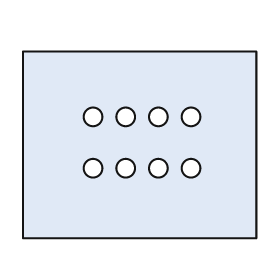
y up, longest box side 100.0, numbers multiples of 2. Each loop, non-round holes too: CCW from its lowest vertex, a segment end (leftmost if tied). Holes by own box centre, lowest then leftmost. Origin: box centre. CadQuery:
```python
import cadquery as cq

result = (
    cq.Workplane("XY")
    .moveTo(-50.0, -40.0)
    .lineTo(50.0, -40.0)
    .lineTo(50.0, 40.0)
    .lineTo(-50.0, 40.0)
    .close()
    .moveTo(-20.0, -10.0)
    .circle(4.0)
    .moveTo(-6.0, -10.0)
    .circle(4.0)
    .moveTo(8.0, -10.0)
    .circle(4.0)
    .moveTo(22.0, -10.0)
    .circle(4.0)
    .moveTo(-20.0, 12.0)
    .circle(4.0)
    .moveTo(-6.0, 12.0)
    .circle(4.0)
    .moveTo(8.0, 12.0)
    .circle(4.0)
    .moveTo(22.0, 12.0)
    .circle(4.0)
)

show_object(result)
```